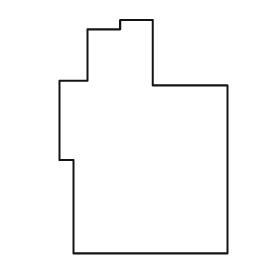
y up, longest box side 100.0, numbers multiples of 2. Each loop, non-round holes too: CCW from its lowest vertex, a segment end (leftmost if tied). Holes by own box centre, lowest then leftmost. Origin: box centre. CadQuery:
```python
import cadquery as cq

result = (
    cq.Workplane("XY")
    .moveTo(-30.0, -50.0)
    .lineTo(36.0, -50.0)
    .lineTo(36.0, 22.0)
    .lineTo(4.0, 22.0)
    .lineTo(4.0, 50.0)
    .lineTo(-10.0, 50.0)
    .lineTo(-10.0, 46.0)
    .lineTo(-24.0, 46.0)
    .lineTo(-24.0, 24.0)
    .lineTo(-36.0, 24.0)
    .lineTo(-36.0, -10.0)
    .lineTo(-30.0, -10.0)
    .close()
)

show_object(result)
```